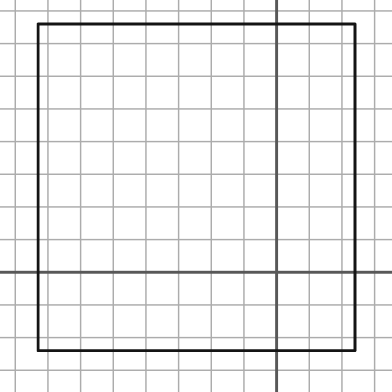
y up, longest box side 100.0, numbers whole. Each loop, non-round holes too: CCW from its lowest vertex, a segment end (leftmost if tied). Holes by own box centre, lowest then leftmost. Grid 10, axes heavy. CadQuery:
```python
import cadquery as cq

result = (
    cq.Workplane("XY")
    .moveTo(-73.0, -24.0)
    .lineTo(24.0, -24.0)
    .lineTo(24.0, 76.0)
    .lineTo(-73.0, 76.0)
    .close()
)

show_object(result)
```